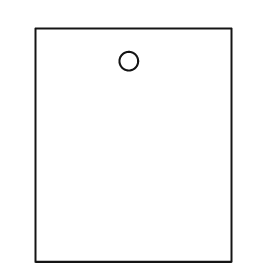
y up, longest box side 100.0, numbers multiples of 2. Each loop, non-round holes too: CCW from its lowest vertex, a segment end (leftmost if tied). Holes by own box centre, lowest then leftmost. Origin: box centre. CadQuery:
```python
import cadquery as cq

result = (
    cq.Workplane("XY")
    .moveTo(-42.0, -50.0)
    .lineTo(42.0, -50.0)
    .lineTo(42.0, 50.0)
    .lineTo(-42.0, 50.0)
    .close()
    .moveTo(-2.0, 36.0)
    .circle(4.0)
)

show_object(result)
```